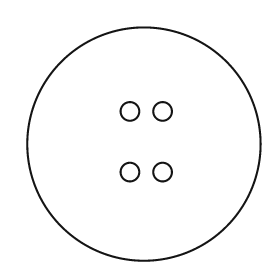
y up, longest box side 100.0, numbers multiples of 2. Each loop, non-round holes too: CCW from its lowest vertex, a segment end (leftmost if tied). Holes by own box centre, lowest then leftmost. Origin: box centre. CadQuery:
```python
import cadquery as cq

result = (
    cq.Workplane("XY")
    .moveTo(0.0, 0.0)
    .circle(50.0)
    .moveTo(-6.0, -12.0)
    .circle(4.0)
    .moveTo(8.0, -12.0)
    .circle(4.0)
    .moveTo(-6.0, 14.0)
    .circle(4.0)
    .moveTo(8.0, 14.0)
    .circle(4.0)
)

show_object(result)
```